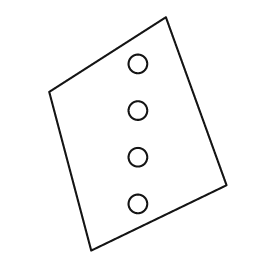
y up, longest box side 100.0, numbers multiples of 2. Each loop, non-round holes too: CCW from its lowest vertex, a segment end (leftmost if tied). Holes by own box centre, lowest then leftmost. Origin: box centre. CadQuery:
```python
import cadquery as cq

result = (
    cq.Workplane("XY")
    .moveTo(-20.0, -50.0)
    .lineTo(38.0, -22.0)
    .lineTo(12.0, 50.0)
    .lineTo(-38.0, 18.0)
    .close()
    .moveTo(0.0, -30.0)
    .circle(4.0)
    .moveTo(0.0, -10.0)
    .circle(4.0)
    .moveTo(0.0, 10.0)
    .circle(4.0)
    .moveTo(0.0, 30.0)
    .circle(4.0)
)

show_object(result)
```